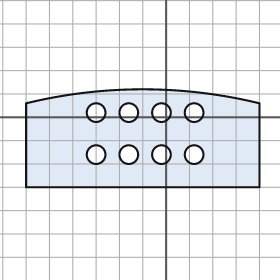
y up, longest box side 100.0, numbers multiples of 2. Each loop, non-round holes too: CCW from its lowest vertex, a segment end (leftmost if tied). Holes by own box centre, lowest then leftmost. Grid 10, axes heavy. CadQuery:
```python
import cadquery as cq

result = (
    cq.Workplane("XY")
    .moveTo(-60.0, -30.0)
    .lineTo(40.0, -30.0)
    .lineTo(40.0, 6.0)
    .threePointArc((-10.0, 12.0), (-60.0, 6.0))
    .close()
    .moveTo(-30.0, -16.0)
    .circle(4.0)
    .moveTo(-16.0, -16.0)
    .circle(4.0)
    .moveTo(-2.0, -16.0)
    .circle(4.0)
    .moveTo(12.0, -16.0)
    .circle(4.0)
    .moveTo(-30.0, 2.0)
    .circle(4.0)
    .moveTo(-16.0, 2.0)
    .circle(4.0)
    .moveTo(-2.0, 2.0)
    .circle(4.0)
    .moveTo(12.0, 2.0)
    .circle(4.0)
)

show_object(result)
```